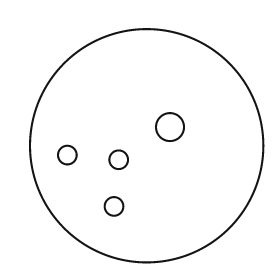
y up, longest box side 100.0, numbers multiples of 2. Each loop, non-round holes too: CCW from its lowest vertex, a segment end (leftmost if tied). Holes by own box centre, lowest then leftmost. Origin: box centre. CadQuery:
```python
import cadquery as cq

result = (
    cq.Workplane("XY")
    .moveTo(0.0, 0.0)
    .circle(50.0)
    .moveTo(-14.0, -26.0)
    .circle(4.0)
    .moveTo(-12.0, -6.0)
    .circle(4.0)
    .moveTo(-34.0, -4.0)
    .circle(4.0)
    .moveTo(10.0, 8.0)
    .circle(6.0)
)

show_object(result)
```